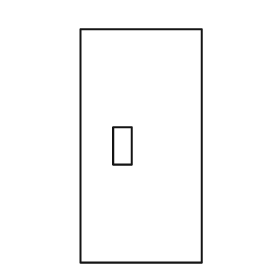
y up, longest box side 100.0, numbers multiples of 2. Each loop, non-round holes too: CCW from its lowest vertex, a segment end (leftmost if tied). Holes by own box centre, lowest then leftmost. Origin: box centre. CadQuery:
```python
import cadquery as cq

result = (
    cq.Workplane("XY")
    .moveTo(-26.0, -50.0)
    .lineTo(26.0, -50.0)
    .lineTo(26.0, 50.0)
    .lineTo(-26.0, 50.0)
    .close()
    .moveTo(-12.0, -8.0)
    .lineTo(-4.0, -8.0)
    .lineTo(-4.0, 8.0)
    .lineTo(-12.0, 8.0)
    .close()
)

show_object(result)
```